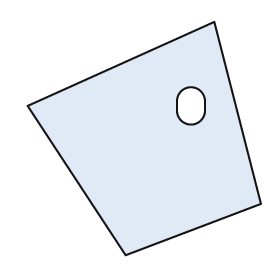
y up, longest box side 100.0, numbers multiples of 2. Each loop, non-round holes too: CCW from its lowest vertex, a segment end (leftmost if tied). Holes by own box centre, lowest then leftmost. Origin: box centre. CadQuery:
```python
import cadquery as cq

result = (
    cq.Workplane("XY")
    .moveTo(-8.0, -50.0)
    .lineTo(50.0, -28.0)
    .lineTo(30.0, 50.0)
    .lineTo(-50.0, 14.0)
    .close()
    .moveTo(14.0, 12.0)
    .threePointArc((20.0, 6.0), (26.0, 12.0))
    .lineTo(26.0, 16.0)
    .threePointArc((20.0, 22.0), (14.0, 16.0))
    .close()
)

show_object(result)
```